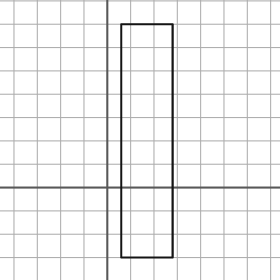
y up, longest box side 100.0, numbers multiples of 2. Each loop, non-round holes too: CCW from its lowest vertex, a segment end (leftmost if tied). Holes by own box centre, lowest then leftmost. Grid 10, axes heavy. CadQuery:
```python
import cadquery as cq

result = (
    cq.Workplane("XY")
    .moveTo(6.0, -30.0)
    .lineTo(28.0, -30.0)
    .lineTo(28.0, 70.0)
    .lineTo(6.0, 70.0)
    .close()
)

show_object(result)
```